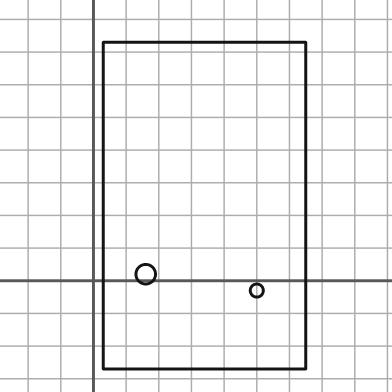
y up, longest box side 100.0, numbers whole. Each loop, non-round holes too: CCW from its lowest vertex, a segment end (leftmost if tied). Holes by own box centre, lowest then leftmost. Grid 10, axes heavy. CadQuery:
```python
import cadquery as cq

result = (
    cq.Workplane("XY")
    .moveTo(3.0, -27.0)
    .lineTo(65.0, -27.0)
    .lineTo(65.0, 73.0)
    .lineTo(3.0, 73.0)
    .close()
    .moveTo(50.0, -3.0)
    .circle(2.0)
    .moveTo(16.0, 2.0)
    .circle(3.0)
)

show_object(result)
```